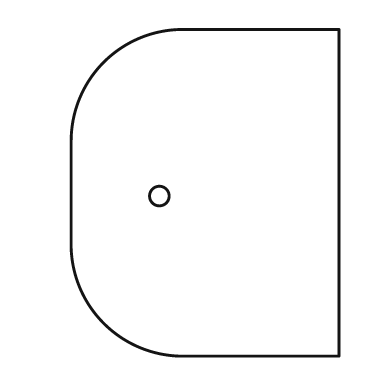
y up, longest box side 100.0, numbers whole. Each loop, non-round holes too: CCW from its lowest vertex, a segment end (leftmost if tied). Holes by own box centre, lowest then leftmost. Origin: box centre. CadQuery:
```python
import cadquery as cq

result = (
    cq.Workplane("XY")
    .moveTo(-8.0, -50.0)
    .lineTo(41.0, -50.0)
    .lineTo(41.0, 50.0)
    .lineTo(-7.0, 50.0)
    .threePointArc((-31.0, 40.0), (-41.0, 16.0))
    .lineTo(-41.0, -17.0)
    .threePointArc((-31.0, -40.0), (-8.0, -50.0))
    .close()
    .moveTo(-14.0, -1.0)
    .circle(3.0)
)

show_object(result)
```